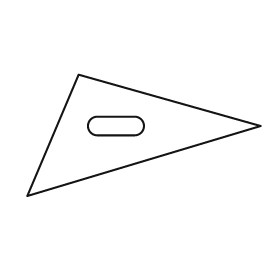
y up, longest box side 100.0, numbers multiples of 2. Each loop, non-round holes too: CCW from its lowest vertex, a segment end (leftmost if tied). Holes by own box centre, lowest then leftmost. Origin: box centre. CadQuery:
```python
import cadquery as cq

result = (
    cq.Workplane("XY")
    .moveTo(-50.0, -26.0)
    .lineTo(50.0, 4.0)
    .lineTo(-28.0, 26.0)
    .close()
    .moveTo(-20.0, 0.0)
    .lineTo(-4.0, 0.0)
    .threePointArc((0.0, 4.0), (-4.0, 8.0))
    .lineTo(-20.0, 8.0)
    .threePointArc((-24.0, 4.0), (-20.0, 0.0))
    .close()
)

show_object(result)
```